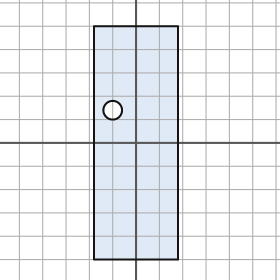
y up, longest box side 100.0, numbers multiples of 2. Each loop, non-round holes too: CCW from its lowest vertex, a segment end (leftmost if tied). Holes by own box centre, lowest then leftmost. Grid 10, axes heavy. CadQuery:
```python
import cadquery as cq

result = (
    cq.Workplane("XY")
    .moveTo(-18.0, -50.0)
    .lineTo(18.0, -50.0)
    .lineTo(18.0, 50.0)
    .lineTo(-18.0, 50.0)
    .close()
    .moveTo(-10.0, 14.0)
    .circle(4.0)
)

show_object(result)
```